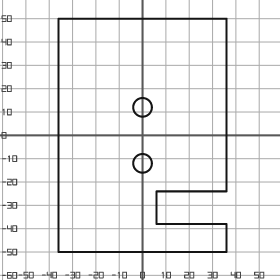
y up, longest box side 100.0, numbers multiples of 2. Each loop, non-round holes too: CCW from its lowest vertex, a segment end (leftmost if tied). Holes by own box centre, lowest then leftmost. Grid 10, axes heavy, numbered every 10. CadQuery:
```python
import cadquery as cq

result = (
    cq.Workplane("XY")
    .moveTo(-36.0, -50.0)
    .lineTo(36.0, -50.0)
    .lineTo(36.0, -38.0)
    .lineTo(6.0, -38.0)
    .lineTo(6.0, -24.0)
    .lineTo(36.0, -24.0)
    .lineTo(36.0, 50.0)
    .lineTo(-36.0, 50.0)
    .close()
    .moveTo(0.0, -12.0)
    .circle(4.0)
    .moveTo(0.0, 12.0)
    .circle(4.0)
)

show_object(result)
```